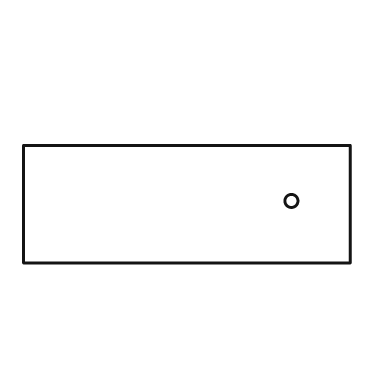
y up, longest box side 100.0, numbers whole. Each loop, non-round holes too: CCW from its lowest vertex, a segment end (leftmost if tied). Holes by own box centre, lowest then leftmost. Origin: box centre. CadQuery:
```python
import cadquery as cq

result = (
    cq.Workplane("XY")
    .moveTo(-50.0, -18.0)
    .lineTo(50.0, -18.0)
    .lineTo(50.0, 18.0)
    .lineTo(-50.0, 18.0)
    .close()
    .moveTo(32.0, 1.0)
    .circle(2.0)
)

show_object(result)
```